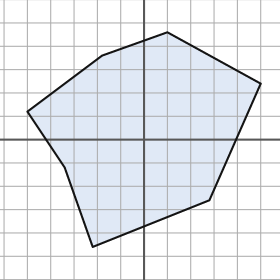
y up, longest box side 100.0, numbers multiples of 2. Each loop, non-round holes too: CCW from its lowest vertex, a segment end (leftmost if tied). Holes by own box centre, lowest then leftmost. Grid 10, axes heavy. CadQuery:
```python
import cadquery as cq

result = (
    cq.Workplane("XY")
    .moveTo(-22.0, -46.0)
    .lineTo(28.0, -26.0)
    .lineTo(50.0, 24.0)
    .lineTo(10.0, 46.0)
    .lineTo(-18.0, 36.0)
    .lineTo(-50.0, 12.0)
    .lineTo(-34.0, -12.0)
    .close()
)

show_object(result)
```